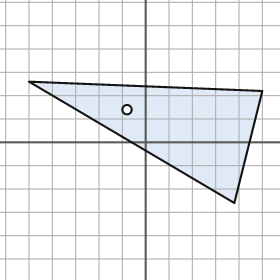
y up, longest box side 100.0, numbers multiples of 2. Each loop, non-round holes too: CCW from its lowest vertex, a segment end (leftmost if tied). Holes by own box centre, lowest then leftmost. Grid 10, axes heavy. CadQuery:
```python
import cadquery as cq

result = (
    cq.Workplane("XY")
    .moveTo(38.0, -26.0)
    .lineTo(50.0, 22.0)
    .lineTo(-50.0, 26.0)
    .close()
    .moveTo(-8.0, 14.0)
    .circle(2.0)
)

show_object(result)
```